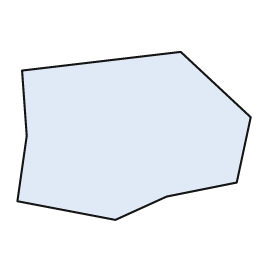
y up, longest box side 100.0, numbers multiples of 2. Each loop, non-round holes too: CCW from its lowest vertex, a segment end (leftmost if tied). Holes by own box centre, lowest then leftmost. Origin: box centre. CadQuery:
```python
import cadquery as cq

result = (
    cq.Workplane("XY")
    .moveTo(-8.0, -36.0)
    .lineTo(14.0, -26.0)
    .lineTo(44.0, -20.0)
    .lineTo(50.0, 8.0)
    .lineTo(20.0, 36.0)
    .lineTo(-48.0, 28.0)
    .lineTo(-46.0, 0.0)
    .lineTo(-50.0, -28.0)
    .close()
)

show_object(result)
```